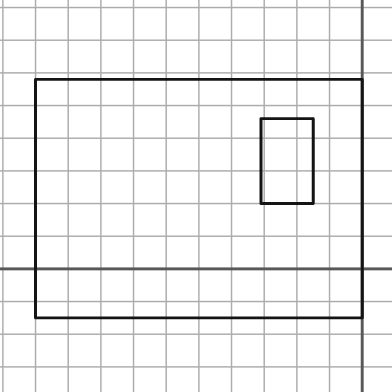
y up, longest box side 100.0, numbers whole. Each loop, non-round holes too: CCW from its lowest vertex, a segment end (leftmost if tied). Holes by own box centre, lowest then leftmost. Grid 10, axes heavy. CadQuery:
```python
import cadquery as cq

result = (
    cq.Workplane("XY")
    .moveTo(-100.0, -15.0)
    .lineTo(0.0, -15.0)
    .lineTo(0.0, 58.0)
    .lineTo(-100.0, 58.0)
    .close()
    .moveTo(-31.0, 20.0)
    .lineTo(-15.0, 20.0)
    .lineTo(-15.0, 46.0)
    .lineTo(-31.0, 46.0)
    .close()
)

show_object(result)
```